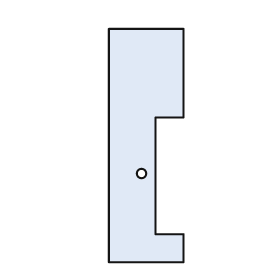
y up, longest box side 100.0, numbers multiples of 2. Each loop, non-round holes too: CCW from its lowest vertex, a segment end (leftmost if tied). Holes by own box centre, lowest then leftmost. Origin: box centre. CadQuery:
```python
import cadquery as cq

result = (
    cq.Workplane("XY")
    .moveTo(-16.0, -50.0)
    .lineTo(16.0, -50.0)
    .lineTo(16.0, -38.0)
    .lineTo(4.0, -38.0)
    .lineTo(4.0, 12.0)
    .lineTo(16.0, 12.0)
    .lineTo(16.0, 50.0)
    .lineTo(-16.0, 50.0)
    .close()
    .moveTo(-2.0, -12.0)
    .circle(2.0)
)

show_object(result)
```